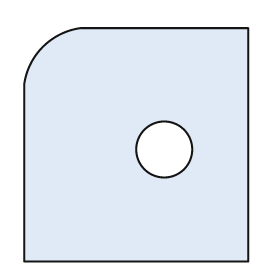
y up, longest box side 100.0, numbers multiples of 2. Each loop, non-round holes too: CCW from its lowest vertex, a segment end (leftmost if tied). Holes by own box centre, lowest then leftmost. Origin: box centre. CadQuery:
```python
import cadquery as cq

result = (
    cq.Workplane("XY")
    .moveTo(-48.0, -50.0)
    .lineTo(48.0, -50.0)
    .lineTo(48.0, 50.0)
    .lineTo(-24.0, 50.0)
    .threePointArc((-40.0, 42.0), (-48.0, 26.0))
    .close()
    .moveTo(12.0, -2.0)
    .circle(12.0)
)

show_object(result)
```